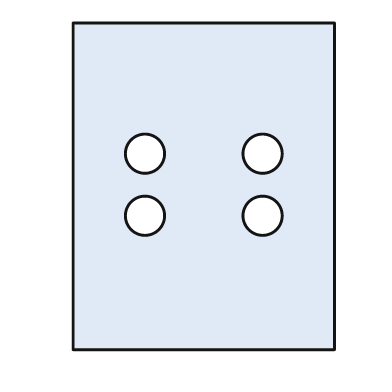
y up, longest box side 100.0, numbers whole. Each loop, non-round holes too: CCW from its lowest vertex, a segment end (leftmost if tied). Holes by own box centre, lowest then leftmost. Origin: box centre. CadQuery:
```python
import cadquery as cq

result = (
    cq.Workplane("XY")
    .moveTo(-40.0, -50.0)
    .lineTo(40.0, -50.0)
    .lineTo(40.0, 50.0)
    .lineTo(-40.0, 50.0)
    .close()
    .moveTo(-18.0, -9.0)
    .circle(6.0)
    .moveTo(18.0, -9.0)
    .circle(6.0)
    .moveTo(-18.0, 10.0)
    .circle(6.0)
    .moveTo(18.0, 10.0)
    .circle(6.0)
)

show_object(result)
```